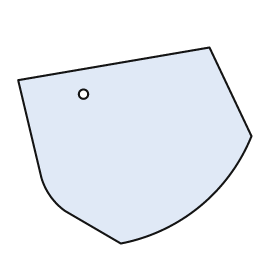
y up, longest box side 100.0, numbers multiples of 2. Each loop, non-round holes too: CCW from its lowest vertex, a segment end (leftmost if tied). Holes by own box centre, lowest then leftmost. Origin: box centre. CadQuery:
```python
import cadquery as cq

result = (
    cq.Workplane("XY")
    .moveTo(-6.0, -42.0)
    .threePointArc((28.0, -26.0), (50.0, 4.0))
    .lineTo(32.0, 42.0)
    .lineTo(-50.0, 28.0)
    .lineTo(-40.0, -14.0)
    .threePointArc((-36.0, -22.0), (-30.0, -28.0))
    .close()
    .moveTo(-22.0, 22.0)
    .circle(2.0)
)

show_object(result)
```